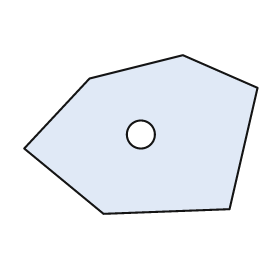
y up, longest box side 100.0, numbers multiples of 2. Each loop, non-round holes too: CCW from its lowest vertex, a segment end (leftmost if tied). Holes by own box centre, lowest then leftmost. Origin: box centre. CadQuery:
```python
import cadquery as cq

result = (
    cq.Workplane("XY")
    .moveTo(-16.0, -34.0)
    .lineTo(38.0, -32.0)
    .lineTo(50.0, 20.0)
    .lineTo(18.0, 34.0)
    .lineTo(-22.0, 24.0)
    .lineTo(-50.0, -6.0)
    .close()
    .moveTo(0.0, 0.0)
    .circle(6.0)
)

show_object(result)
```